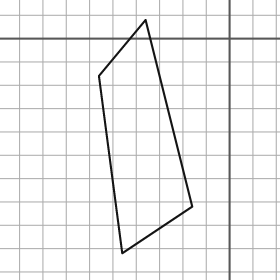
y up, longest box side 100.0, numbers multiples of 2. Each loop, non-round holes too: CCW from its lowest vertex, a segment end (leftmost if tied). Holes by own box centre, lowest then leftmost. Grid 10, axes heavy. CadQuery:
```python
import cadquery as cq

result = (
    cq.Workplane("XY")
    .moveTo(-46.0, -92.0)
    .lineTo(-16.0, -72.0)
    .lineTo(-36.0, 8.0)
    .lineTo(-56.0, -16.0)
    .close()
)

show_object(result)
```